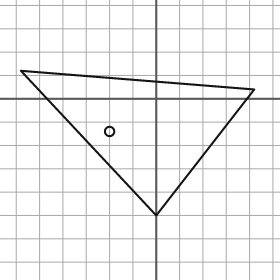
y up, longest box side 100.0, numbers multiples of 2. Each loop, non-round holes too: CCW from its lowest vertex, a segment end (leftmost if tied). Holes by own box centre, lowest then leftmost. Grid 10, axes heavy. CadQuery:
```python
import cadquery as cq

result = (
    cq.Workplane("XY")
    .moveTo(0.0, -50.0)
    .lineTo(42.0, 4.0)
    .lineTo(-58.0, 12.0)
    .close()
    .moveTo(-20.0, -14.0)
    .circle(2.0)
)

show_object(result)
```